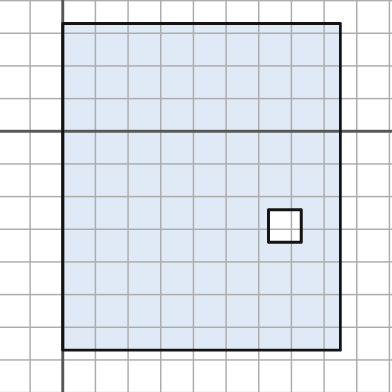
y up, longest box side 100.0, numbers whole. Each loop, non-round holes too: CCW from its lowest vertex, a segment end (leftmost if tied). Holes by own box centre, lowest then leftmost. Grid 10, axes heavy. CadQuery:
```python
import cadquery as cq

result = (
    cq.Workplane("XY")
    .moveTo(0.0, -67.0)
    .lineTo(85.0, -67.0)
    .lineTo(85.0, 33.0)
    .lineTo(0.0, 33.0)
    .close()
    .moveTo(63.0, -34.0)
    .lineTo(73.0, -34.0)
    .lineTo(73.0, -24.0)
    .lineTo(63.0, -24.0)
    .close()
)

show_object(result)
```